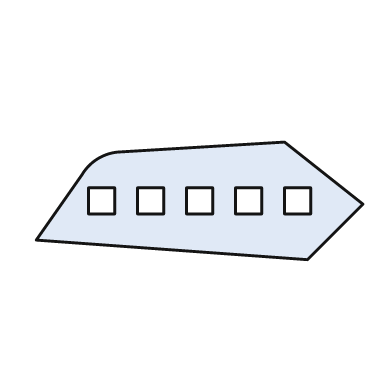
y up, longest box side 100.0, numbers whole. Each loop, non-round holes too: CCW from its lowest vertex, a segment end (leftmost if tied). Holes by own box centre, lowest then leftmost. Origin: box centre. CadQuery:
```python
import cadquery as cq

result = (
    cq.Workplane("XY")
    .moveTo(33.0, -18.0)
    .lineTo(50.0, -1.0)
    .lineTo(26.0, 18.0)
    .lineTo(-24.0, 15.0)
    .threePointArc((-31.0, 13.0), (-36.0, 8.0))
    .lineTo(-50.0, -12.0)
    .close()
    .moveTo(-34.0, -4.0)
    .lineTo(-26.0, -4.0)
    .lineTo(-26.0, 4.0)
    .lineTo(-34.0, 4.0)
    .close()
    .moveTo(-19.0, -4.0)
    .lineTo(-11.0, -4.0)
    .lineTo(-11.0, 4.0)
    .lineTo(-19.0, 4.0)
    .close()
    .moveTo(-4.0, -4.0)
    .lineTo(4.0, -4.0)
    .lineTo(4.0, 4.0)
    .lineTo(-4.0, 4.0)
    .close()
    .moveTo(11.0, -4.0)
    .lineTo(19.0, -4.0)
    .lineTo(19.0, 4.0)
    .lineTo(11.0, 4.0)
    .close()
    .moveTo(26.0, -4.0)
    .lineTo(34.0, -4.0)
    .lineTo(34.0, 4.0)
    .lineTo(26.0, 4.0)
    .close()
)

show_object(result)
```